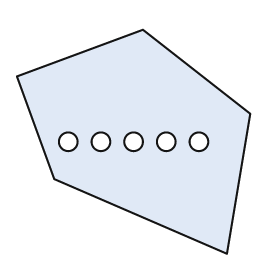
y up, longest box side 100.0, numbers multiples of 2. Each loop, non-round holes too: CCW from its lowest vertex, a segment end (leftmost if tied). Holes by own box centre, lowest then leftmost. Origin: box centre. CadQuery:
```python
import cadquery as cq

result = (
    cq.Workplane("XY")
    .moveTo(40.0, -48.0)
    .lineTo(50.0, 12.0)
    .lineTo(4.0, 48.0)
    .lineTo(-50.0, 28.0)
    .lineTo(-34.0, -16.0)
    .close()
    .moveTo(-28.0, 0.0)
    .circle(4.0)
    .moveTo(-14.0, 0.0)
    .circle(4.0)
    .moveTo(0.0, 0.0)
    .circle(4.0)
    .moveTo(14.0, 0.0)
    .circle(4.0)
    .moveTo(28.0, 0.0)
    .circle(4.0)
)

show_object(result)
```